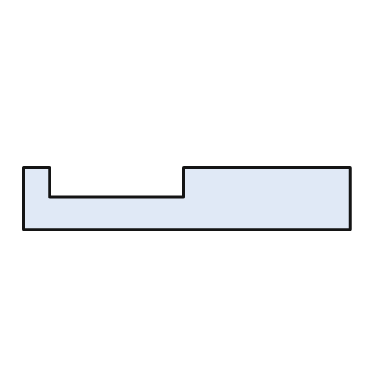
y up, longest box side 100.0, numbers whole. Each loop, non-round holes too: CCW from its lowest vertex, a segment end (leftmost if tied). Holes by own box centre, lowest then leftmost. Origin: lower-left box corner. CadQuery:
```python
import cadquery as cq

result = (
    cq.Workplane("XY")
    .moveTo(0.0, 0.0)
    .lineTo(100.0, 0.0)
    .lineTo(100.0, 19.0)
    .lineTo(49.0, 19.0)
    .lineTo(49.0, 10.0)
    .lineTo(8.0, 10.0)
    .lineTo(8.0, 19.0)
    .lineTo(0.0, 19.0)
    .close()
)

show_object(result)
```